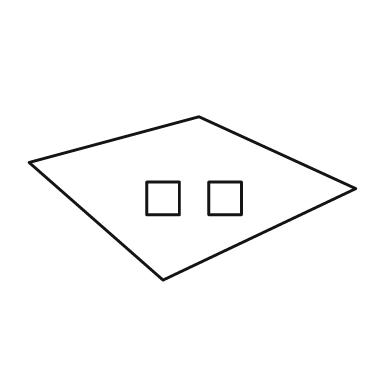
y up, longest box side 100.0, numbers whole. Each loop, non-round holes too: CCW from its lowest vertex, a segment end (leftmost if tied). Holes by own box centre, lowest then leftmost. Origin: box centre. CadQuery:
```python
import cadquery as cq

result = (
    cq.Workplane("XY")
    .moveTo(-9.0, -25.0)
    .lineTo(50.0, 3.0)
    .lineTo(2.0, 25.0)
    .lineTo(-50.0, 11.0)
    .close()
    .moveTo(-14.0, -5.0)
    .lineTo(-4.0, -5.0)
    .lineTo(-4.0, 5.0)
    .lineTo(-14.0, 5.0)
    .close()
    .moveTo(5.0, -5.0)
    .lineTo(15.0, -5.0)
    .lineTo(15.0, 5.0)
    .lineTo(5.0, 5.0)
    .close()
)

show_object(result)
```